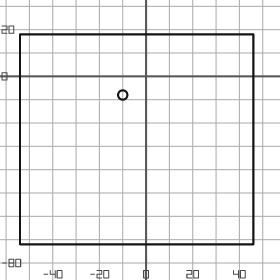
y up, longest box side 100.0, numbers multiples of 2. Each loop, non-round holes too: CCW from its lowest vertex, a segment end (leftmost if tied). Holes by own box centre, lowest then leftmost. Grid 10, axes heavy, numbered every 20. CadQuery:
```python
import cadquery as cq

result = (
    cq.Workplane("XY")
    .moveTo(-54.0, -72.0)
    .lineTo(46.0, -72.0)
    .lineTo(46.0, 18.0)
    .lineTo(-54.0, 18.0)
    .close()
    .moveTo(-10.0, -8.0)
    .circle(2.0)
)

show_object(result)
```